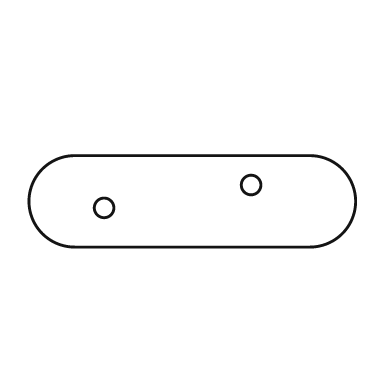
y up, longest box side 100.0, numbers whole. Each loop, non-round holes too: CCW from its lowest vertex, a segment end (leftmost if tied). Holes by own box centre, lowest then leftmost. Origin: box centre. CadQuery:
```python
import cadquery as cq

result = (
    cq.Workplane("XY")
    .moveTo(-36.0, -14.0)
    .lineTo(36.0, -14.0)
    .threePointArc((50.0, 0.0), (36.0, 14.0))
    .lineTo(-36.0, 14.0)
    .threePointArc((-50.0, 0.0), (-36.0, -14.0))
    .close()
    .moveTo(-27.0, -2.0)
    .circle(3.0)
    .moveTo(18.0, 5.0)
    .circle(3.0)
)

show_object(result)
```